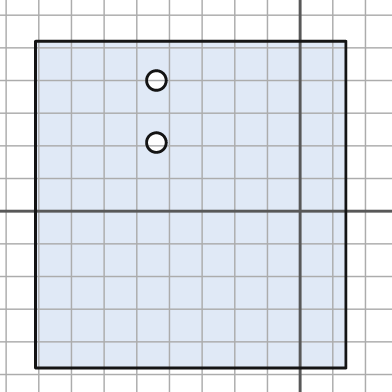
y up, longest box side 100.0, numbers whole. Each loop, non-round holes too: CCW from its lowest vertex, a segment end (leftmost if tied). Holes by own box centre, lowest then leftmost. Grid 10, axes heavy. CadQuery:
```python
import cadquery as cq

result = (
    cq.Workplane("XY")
    .moveTo(-81.0, -48.0)
    .lineTo(14.0, -48.0)
    .lineTo(14.0, 52.0)
    .lineTo(-81.0, 52.0)
    .close()
    .moveTo(-44.0, 21.0)
    .circle(3.0)
    .moveTo(-44.0, 40.0)
    .circle(3.0)
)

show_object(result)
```